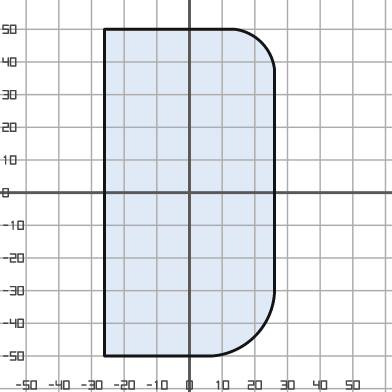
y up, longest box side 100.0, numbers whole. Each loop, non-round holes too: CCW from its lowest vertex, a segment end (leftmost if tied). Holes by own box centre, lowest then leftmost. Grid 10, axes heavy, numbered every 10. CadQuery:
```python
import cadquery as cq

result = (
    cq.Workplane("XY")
    .moveTo(-26.0, -50.0)
    .lineTo(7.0, -50.0)
    .threePointArc((20.0, -44.0), (26.0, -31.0))
    .lineTo(26.0, 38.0)
    .threePointArc((22.0, 46.0), (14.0, 50.0))
    .lineTo(-26.0, 50.0)
    .close()
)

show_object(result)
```